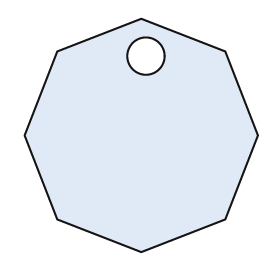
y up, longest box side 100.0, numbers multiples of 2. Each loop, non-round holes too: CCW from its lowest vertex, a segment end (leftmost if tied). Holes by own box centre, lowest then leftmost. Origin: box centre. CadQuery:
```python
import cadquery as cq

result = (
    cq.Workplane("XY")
    .moveTo(0.0, -50.0)
    .lineTo(36.0, -36.0)
    .lineTo(50.0, 0.0)
    .lineTo(36.0, 36.0)
    .lineTo(0.0, 50.0)
    .lineTo(-36.0, 36.0)
    .lineTo(-50.0, 0.0)
    .lineTo(-36.0, -36.0)
    .close()
    .moveTo(2.0, 34.0)
    .circle(8.0)
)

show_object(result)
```